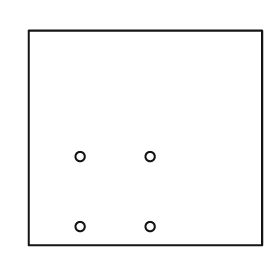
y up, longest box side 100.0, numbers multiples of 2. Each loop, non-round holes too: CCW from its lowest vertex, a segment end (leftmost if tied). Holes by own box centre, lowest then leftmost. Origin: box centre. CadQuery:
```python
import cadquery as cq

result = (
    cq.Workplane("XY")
    .moveTo(-50.0, -46.0)
    .lineTo(50.0, -46.0)
    .lineTo(50.0, 46.0)
    .lineTo(-50.0, 46.0)
    .close()
    .moveTo(-28.0, -38.0)
    .circle(2.0)
    .moveTo(2.0, -38.0)
    .circle(2.0)
    .moveTo(-28.0, -8.0)
    .circle(2.0)
    .moveTo(2.0, -8.0)
    .circle(2.0)
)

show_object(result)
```